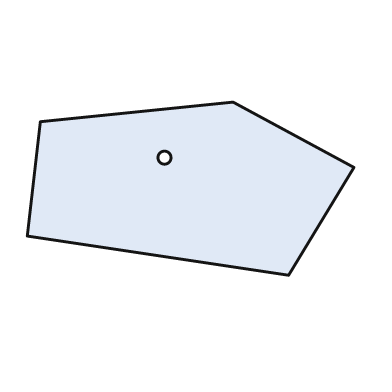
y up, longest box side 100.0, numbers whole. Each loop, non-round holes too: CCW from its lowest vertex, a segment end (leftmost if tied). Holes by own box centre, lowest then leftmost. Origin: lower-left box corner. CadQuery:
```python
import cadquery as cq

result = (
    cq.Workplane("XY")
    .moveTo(80.0, 0.0)
    .lineTo(100.0, 33.0)
    .lineTo(63.0, 53.0)
    .lineTo(4.0, 47.0)
    .lineTo(0.0, 12.0)
    .close()
    .moveTo(42.0, 36.0)
    .circle(2.0)
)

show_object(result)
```